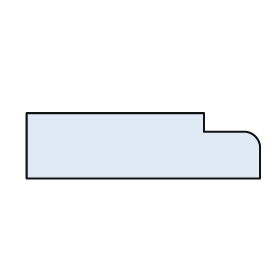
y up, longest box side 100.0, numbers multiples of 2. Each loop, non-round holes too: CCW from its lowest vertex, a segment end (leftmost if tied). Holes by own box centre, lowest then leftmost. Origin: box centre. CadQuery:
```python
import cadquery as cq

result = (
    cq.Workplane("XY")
    .moveTo(-50.0, -14.0)
    .lineTo(50.0, -14.0)
    .lineTo(50.0, 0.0)
    .threePointArc((48.0, 4.0), (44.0, 6.0))
    .lineTo(26.0, 6.0)
    .lineTo(26.0, 14.0)
    .lineTo(-50.0, 14.0)
    .close()
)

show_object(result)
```